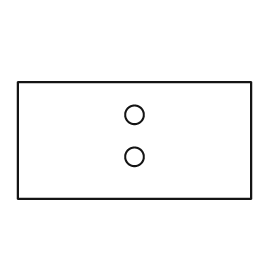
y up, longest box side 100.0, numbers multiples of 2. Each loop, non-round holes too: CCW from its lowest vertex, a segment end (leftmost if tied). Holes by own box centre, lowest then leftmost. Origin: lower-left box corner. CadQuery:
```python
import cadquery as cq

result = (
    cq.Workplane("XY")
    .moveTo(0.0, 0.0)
    .lineTo(100.0, 0.0)
    .lineTo(100.0, 50.0)
    .lineTo(0.0, 50.0)
    .close()
    .moveTo(50.0, 18.0)
    .circle(4.0)
    .moveTo(50.0, 36.0)
    .circle(4.0)
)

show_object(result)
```